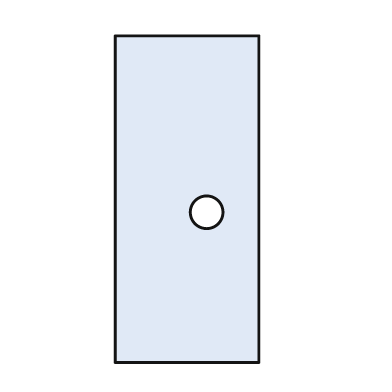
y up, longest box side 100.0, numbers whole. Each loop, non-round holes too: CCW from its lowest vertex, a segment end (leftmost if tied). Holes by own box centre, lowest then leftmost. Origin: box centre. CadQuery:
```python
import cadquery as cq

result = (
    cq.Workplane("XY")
    .moveTo(-22.0, -50.0)
    .lineTo(22.0, -50.0)
    .lineTo(22.0, 50.0)
    .lineTo(-22.0, 50.0)
    .close()
    .moveTo(6.0, -4.0)
    .circle(5.0)
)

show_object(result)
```